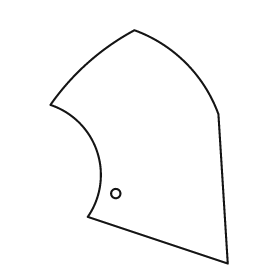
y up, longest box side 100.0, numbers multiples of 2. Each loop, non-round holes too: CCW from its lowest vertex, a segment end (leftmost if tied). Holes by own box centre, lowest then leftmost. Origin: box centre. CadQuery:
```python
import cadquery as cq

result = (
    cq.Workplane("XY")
    .moveTo(38.0, -50.0)
    .lineTo(34.0, 14.0)
    .threePointArc((20.0, 36.0), (-2.0, 50.0))
    .threePointArc((-22.0, 36.0), (-38.0, 18.0))
    .threePointArc((-18.0, -2.0), (-22.0, -30.0))
    .close()
    .moveTo(-10.0, -20.0)
    .circle(2.0)
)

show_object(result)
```